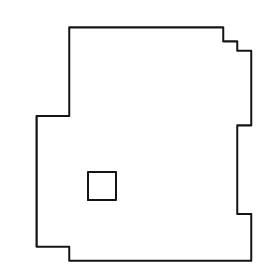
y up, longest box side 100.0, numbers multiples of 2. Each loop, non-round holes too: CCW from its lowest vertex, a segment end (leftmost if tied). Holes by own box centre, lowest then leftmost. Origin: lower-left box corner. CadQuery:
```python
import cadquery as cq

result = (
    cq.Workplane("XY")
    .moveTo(14.0, 0.0)
    .lineTo(92.0, 0.0)
    .lineTo(92.0, 20.0)
    .lineTo(86.0, 20.0)
    .lineTo(86.0, 58.0)
    .lineTo(92.0, 58.0)
    .lineTo(92.0, 90.0)
    .lineTo(86.0, 90.0)
    .lineTo(86.0, 94.0)
    .lineTo(80.0, 94.0)
    .lineTo(80.0, 100.0)
    .lineTo(14.0, 100.0)
    .lineTo(14.0, 62.0)
    .lineTo(0.0, 62.0)
    .lineTo(0.0, 6.0)
    .lineTo(14.0, 6.0)
    .close()
    .moveTo(22.0, 26.0)
    .lineTo(34.0, 26.0)
    .lineTo(34.0, 38.0)
    .lineTo(22.0, 38.0)
    .close()
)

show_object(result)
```